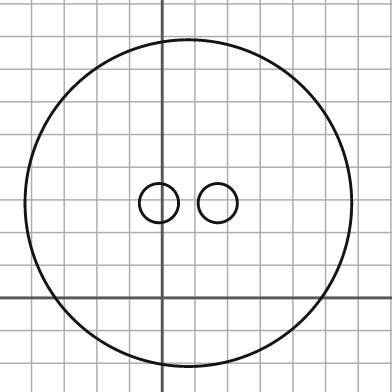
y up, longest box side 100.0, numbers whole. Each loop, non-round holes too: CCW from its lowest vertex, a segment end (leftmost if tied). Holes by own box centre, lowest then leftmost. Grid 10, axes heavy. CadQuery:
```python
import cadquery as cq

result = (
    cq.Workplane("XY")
    .moveTo(8.0, 29.0)
    .circle(50.0)
    .moveTo(-1.0, 29.0)
    .circle(6.0)
    .moveTo(17.0, 29.0)
    .circle(6.0)
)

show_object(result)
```